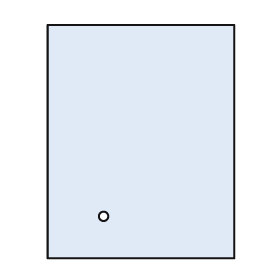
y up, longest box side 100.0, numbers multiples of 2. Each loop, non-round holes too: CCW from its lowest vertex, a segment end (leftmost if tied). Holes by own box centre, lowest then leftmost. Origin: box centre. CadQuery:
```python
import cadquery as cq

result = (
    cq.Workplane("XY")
    .moveTo(-40.0, -50.0)
    .lineTo(40.0, -50.0)
    .lineTo(40.0, 50.0)
    .lineTo(-40.0, 50.0)
    .close()
    .moveTo(-16.0, -32.0)
    .circle(2.0)
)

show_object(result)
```